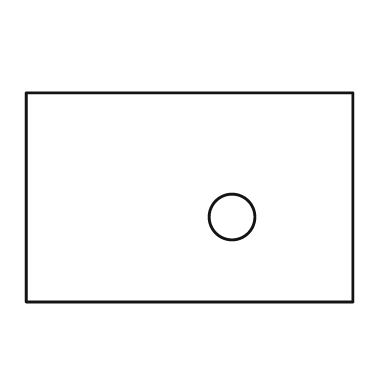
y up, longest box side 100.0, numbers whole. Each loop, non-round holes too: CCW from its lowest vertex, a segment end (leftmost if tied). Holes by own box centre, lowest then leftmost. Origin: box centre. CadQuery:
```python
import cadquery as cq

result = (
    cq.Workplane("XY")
    .moveTo(-50.0, -32.0)
    .lineTo(50.0, -32.0)
    .lineTo(50.0, 32.0)
    .lineTo(-50.0, 32.0)
    .close()
    .moveTo(13.0, -6.0)
    .circle(7.0)
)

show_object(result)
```